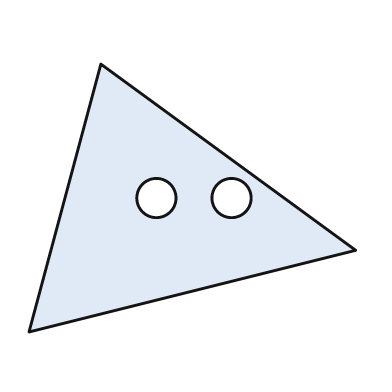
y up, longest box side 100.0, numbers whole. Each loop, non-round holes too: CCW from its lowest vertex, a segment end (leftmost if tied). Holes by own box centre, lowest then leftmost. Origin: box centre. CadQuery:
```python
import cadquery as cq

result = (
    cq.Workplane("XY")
    .moveTo(-50.0, -41.0)
    .lineTo(50.0, -16.0)
    .lineTo(-28.0, 41.0)
    .close()
    .moveTo(-11.0, 0.0)
    .circle(6.0)
    .moveTo(12.0, 0.0)
    .circle(6.0)
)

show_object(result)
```